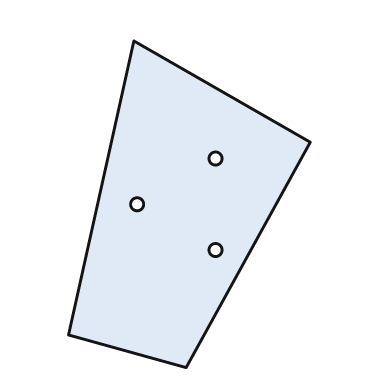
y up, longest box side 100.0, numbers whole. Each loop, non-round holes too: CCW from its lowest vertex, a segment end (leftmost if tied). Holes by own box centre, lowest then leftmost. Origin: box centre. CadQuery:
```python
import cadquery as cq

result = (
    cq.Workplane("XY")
    .moveTo(-1.0, -50.0)
    .lineTo(37.0, 19.0)
    .lineTo(-17.0, 50.0)
    .lineTo(-37.0, -40.0)
    .close()
    .moveTo(8.0, -14.0)
    .circle(2.0)
    .moveTo(-16.0, 0.0)
    .circle(2.0)
    .moveTo(8.0, 14.0)
    .circle(2.0)
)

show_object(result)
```